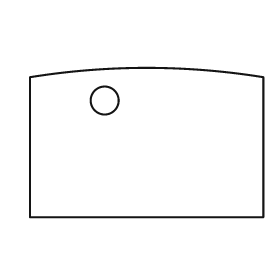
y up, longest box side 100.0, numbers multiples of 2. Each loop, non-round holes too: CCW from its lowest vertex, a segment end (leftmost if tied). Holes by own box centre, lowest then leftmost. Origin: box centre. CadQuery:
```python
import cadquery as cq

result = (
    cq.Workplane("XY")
    .moveTo(-50.0, -32.0)
    .lineTo(50.0, -32.0)
    .lineTo(50.0, 28.0)
    .threePointArc((0.0, 32.0), (-50.0, 28.0))
    .close()
    .moveTo(-18.0, 18.0)
    .circle(6.0)
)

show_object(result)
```